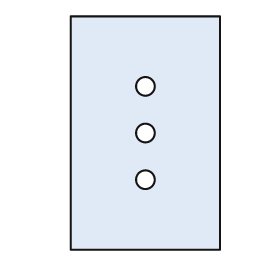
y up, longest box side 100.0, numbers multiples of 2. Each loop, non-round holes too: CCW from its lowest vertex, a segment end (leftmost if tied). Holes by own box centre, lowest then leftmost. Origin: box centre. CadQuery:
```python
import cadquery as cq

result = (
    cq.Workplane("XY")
    .moveTo(-32.0, -50.0)
    .lineTo(32.0, -50.0)
    .lineTo(32.0, 50.0)
    .lineTo(-32.0, 50.0)
    .close()
    .moveTo(0.0, -20.0)
    .circle(4.0)
    .moveTo(0.0, 0.0)
    .circle(4.0)
    .moveTo(0.0, 20.0)
    .circle(4.0)
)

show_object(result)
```